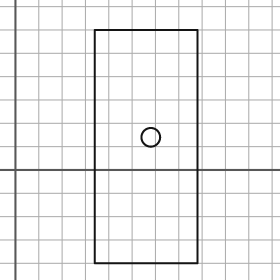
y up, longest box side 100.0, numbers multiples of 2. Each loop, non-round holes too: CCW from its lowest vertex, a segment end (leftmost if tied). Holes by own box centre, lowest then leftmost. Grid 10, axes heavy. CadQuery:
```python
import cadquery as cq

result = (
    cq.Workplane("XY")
    .moveTo(34.0, -40.0)
    .lineTo(78.0, -40.0)
    .lineTo(78.0, 60.0)
    .lineTo(34.0, 60.0)
    .close()
    .moveTo(58.0, 14.0)
    .circle(4.0)
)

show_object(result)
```